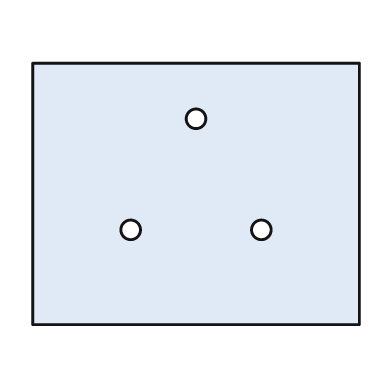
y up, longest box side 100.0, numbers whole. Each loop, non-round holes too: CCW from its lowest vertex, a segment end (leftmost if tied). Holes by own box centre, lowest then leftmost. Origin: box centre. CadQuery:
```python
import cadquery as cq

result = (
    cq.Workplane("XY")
    .moveTo(-50.0, -40.0)
    .lineTo(50.0, -40.0)
    .lineTo(50.0, 40.0)
    .lineTo(-50.0, 40.0)
    .close()
    .moveTo(-20.0, -11.0)
    .circle(3.0)
    .moveTo(20.0, -11.0)
    .circle(3.0)
    .moveTo(0.0, 23.0)
    .circle(3.0)
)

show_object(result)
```